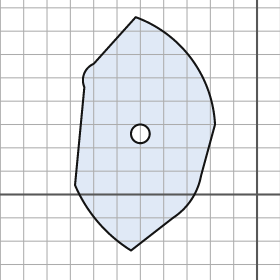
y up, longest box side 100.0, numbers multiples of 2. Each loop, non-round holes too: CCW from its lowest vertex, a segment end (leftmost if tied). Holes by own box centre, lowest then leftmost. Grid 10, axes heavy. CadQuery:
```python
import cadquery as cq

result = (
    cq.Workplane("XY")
    .moveTo(-54.0, -24.0)
    .lineTo(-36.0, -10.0)
    .threePointArc((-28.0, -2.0), (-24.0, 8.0))
    .lineTo(-18.0, 30.0)
    .threePointArc((-28.0, 58.0), (-52.0, 76.0))
    .lineTo(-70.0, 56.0)
    .threePointArc((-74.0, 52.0), (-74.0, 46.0))
    .lineTo(-78.0, 4.0)
    .threePointArc((-68.0, -12.0), (-54.0, -24.0))
    .close()
    .moveTo(-50.0, 26.0)
    .circle(4.0)
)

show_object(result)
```